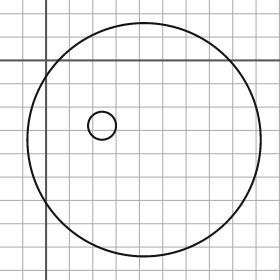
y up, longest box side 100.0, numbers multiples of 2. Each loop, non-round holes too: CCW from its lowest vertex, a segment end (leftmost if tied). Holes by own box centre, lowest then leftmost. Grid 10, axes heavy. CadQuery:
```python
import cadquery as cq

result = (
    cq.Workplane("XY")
    .moveTo(42.0, -34.0)
    .circle(50.0)
    .moveTo(24.0, -28.0)
    .circle(6.0)
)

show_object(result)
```